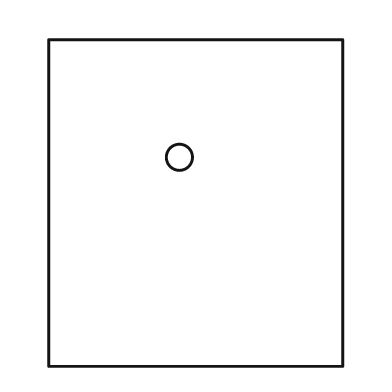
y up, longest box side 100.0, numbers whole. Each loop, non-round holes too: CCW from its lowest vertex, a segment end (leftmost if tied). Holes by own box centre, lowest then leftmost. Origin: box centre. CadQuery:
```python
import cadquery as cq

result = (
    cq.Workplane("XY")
    .moveTo(-45.0, -50.0)
    .lineTo(45.0, -50.0)
    .lineTo(45.0, 50.0)
    .lineTo(-45.0, 50.0)
    .close()
    .moveTo(-5.0, 14.0)
    .circle(4.0)
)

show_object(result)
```